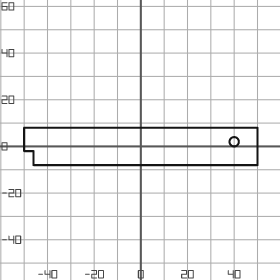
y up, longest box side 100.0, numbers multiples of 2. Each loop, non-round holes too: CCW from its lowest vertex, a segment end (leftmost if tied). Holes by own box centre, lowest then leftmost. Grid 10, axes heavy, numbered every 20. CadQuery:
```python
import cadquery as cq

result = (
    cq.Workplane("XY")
    .moveTo(-46.0, -8.0)
    .lineTo(50.0, -8.0)
    .lineTo(50.0, 8.0)
    .lineTo(-50.0, 8.0)
    .lineTo(-50.0, -2.0)
    .lineTo(-46.0, -2.0)
    .close()
    .moveTo(40.0, 2.0)
    .circle(2.0)
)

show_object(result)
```